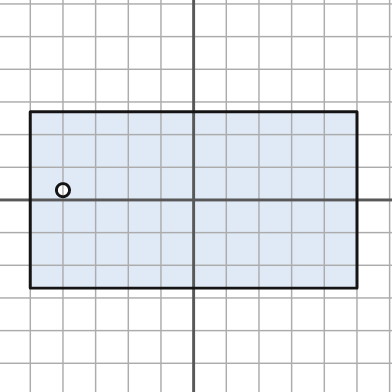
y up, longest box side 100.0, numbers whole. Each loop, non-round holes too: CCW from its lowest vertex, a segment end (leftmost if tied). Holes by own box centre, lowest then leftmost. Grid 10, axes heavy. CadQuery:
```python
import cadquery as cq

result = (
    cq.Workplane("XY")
    .moveTo(-50.0, -27.0)
    .lineTo(50.0, -27.0)
    .lineTo(50.0, 27.0)
    .lineTo(-50.0, 27.0)
    .close()
    .moveTo(-40.0, 3.0)
    .circle(2.0)
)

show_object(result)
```